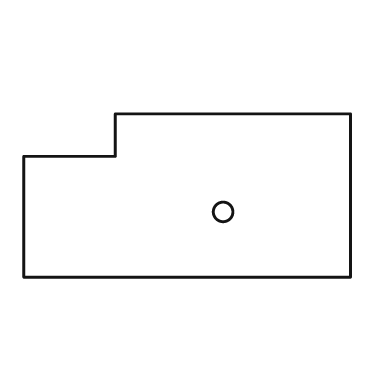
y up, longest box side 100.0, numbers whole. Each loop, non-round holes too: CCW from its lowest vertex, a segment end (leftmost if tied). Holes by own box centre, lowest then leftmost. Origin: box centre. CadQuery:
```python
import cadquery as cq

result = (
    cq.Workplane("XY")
    .moveTo(-50.0, -25.0)
    .lineTo(50.0, -25.0)
    .lineTo(50.0, 25.0)
    .lineTo(-22.0, 25.0)
    .lineTo(-22.0, 12.0)
    .lineTo(-50.0, 12.0)
    .close()
    .moveTo(11.0, -5.0)
    .circle(3.0)
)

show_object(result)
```